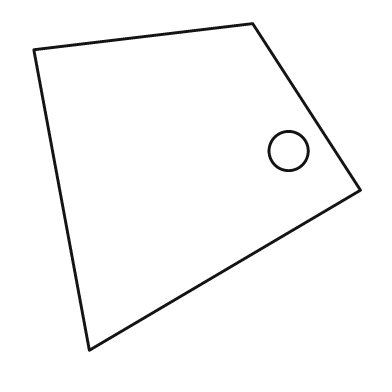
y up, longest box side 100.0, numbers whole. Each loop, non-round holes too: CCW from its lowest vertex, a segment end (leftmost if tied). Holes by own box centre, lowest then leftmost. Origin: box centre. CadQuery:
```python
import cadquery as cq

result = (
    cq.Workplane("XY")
    .moveTo(-33.0, -50.0)
    .lineTo(50.0, -1.0)
    .lineTo(17.0, 50.0)
    .lineTo(-50.0, 42.0)
    .close()
    .moveTo(28.0, 11.0)
    .circle(6.0)
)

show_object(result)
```